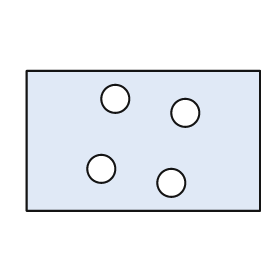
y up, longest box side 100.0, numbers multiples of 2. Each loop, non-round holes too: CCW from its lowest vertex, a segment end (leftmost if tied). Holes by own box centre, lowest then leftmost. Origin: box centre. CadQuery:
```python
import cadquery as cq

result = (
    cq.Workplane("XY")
    .moveTo(-50.0, -30.0)
    .lineTo(50.0, -30.0)
    .lineTo(50.0, 30.0)
    .lineTo(-50.0, 30.0)
    .close()
    .moveTo(12.0, -18.0)
    .circle(6.0)
    .moveTo(-18.0, -12.0)
    .circle(6.0)
    .moveTo(18.0, 12.0)
    .circle(6.0)
    .moveTo(-12.0, 18.0)
    .circle(6.0)
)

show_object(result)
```